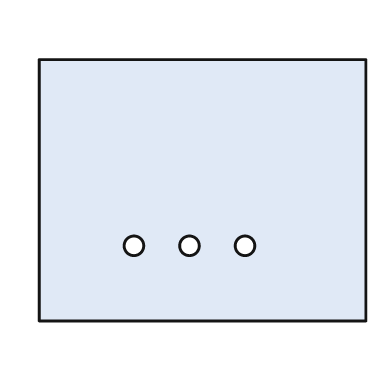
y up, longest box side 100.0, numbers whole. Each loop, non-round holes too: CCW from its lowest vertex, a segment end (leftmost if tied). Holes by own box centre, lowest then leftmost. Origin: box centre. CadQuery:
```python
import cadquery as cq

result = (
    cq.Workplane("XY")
    .moveTo(-50.0, -40.0)
    .lineTo(50.0, -40.0)
    .lineTo(50.0, 40.0)
    .lineTo(-50.0, 40.0)
    .close()
    .moveTo(-21.0, -17.0)
    .circle(3.0)
    .moveTo(-4.0, -17.0)
    .circle(3.0)
    .moveTo(13.0, -17.0)
    .circle(3.0)
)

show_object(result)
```